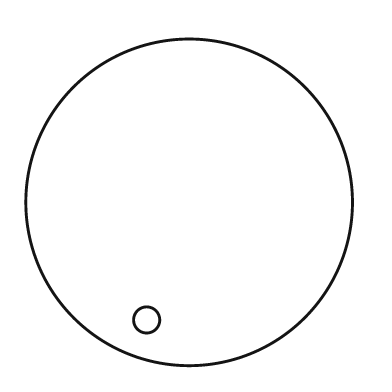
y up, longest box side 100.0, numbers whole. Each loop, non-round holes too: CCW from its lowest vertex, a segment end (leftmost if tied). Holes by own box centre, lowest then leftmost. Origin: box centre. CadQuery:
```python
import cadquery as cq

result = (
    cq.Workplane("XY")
    .moveTo(0.0, 0.0)
    .circle(50.0)
    .moveTo(-13.0, -36.0)
    .circle(4.0)
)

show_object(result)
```